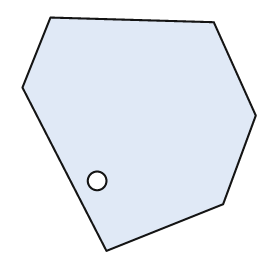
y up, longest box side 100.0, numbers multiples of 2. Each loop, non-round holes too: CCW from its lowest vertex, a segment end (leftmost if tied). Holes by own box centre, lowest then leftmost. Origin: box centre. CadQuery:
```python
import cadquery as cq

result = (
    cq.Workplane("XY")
    .moveTo(-14.0, -50.0)
    .lineTo(36.0, -30.0)
    .lineTo(50.0, 8.0)
    .lineTo(32.0, 48.0)
    .lineTo(-38.0, 50.0)
    .lineTo(-50.0, 20.0)
    .close()
    .moveTo(-18.0, -20.0)
    .circle(4.0)
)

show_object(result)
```